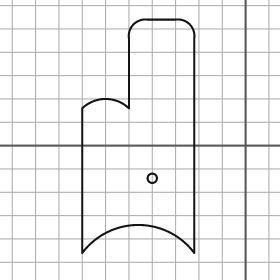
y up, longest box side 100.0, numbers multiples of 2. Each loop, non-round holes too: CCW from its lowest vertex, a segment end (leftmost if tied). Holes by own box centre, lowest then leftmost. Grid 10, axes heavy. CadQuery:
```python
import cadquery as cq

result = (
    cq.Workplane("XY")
    .moveTo(-70.0, -46.0)
    .threePointArc((-46.0, -34.0), (-22.0, -46.0))
    .lineTo(-22.0, 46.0)
    .threePointArc((-24.0, 52.0), (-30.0, 54.0))
    .lineTo(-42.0, 54.0)
    .threePointArc((-48.0, 52.0), (-50.0, 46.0))
    .lineTo(-50.0, 16.0)
    .threePointArc((-60.0, 20.0), (-70.0, 16.0))
    .close()
    .moveTo(-40.0, -14.0)
    .circle(2.0)
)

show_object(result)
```